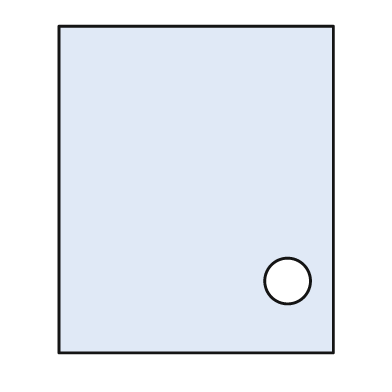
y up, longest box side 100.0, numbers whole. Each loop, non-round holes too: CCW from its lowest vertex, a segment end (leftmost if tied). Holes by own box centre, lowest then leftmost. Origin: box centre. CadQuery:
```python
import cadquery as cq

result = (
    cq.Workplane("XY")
    .moveTo(-42.0, -50.0)
    .lineTo(42.0, -50.0)
    .lineTo(42.0, 50.0)
    .lineTo(-42.0, 50.0)
    .close()
    .moveTo(28.0, -28.0)
    .circle(7.0)
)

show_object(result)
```